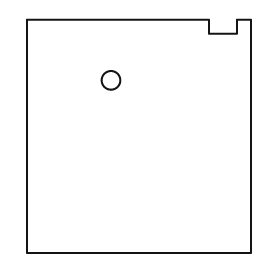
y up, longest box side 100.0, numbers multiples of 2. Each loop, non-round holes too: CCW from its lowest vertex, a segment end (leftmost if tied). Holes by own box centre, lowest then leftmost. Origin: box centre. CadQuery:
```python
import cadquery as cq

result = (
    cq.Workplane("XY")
    .moveTo(-48.0, -50.0)
    .lineTo(48.0, -50.0)
    .lineTo(48.0, 50.0)
    .lineTo(42.0, 50.0)
    .lineTo(42.0, 44.0)
    .lineTo(30.0, 44.0)
    .lineTo(30.0, 50.0)
    .lineTo(-48.0, 50.0)
    .close()
    .moveTo(-12.0, 24.0)
    .circle(4.0)
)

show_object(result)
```